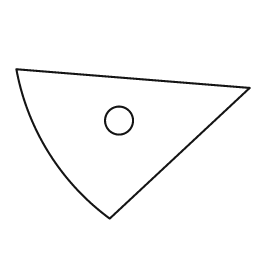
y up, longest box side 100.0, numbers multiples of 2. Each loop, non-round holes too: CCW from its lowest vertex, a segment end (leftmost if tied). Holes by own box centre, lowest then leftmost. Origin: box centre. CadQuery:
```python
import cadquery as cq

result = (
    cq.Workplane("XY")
    .moveTo(-10.0, -32.0)
    .lineTo(50.0, 24.0)
    .lineTo(-50.0, 32.0)
    .threePointArc((-36.0, -4.0), (-10.0, -32.0))
    .close()
    .moveTo(-6.0, 10.0)
    .circle(6.0)
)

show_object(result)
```